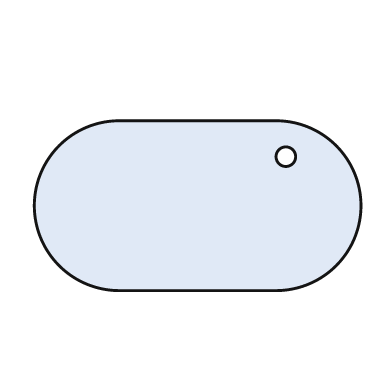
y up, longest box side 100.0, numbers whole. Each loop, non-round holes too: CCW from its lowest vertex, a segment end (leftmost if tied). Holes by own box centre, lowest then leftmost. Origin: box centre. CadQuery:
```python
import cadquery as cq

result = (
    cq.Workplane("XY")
    .moveTo(-24.0, -26.0)
    .lineTo(24.0, -26.0)
    .threePointArc((50.0, 0.0), (24.0, 26.0))
    .lineTo(-24.0, 26.0)
    .threePointArc((-50.0, 0.0), (-24.0, -26.0))
    .close()
    .moveTo(27.0, 15.0)
    .circle(3.0)
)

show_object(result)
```